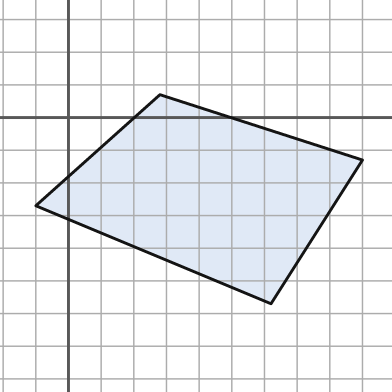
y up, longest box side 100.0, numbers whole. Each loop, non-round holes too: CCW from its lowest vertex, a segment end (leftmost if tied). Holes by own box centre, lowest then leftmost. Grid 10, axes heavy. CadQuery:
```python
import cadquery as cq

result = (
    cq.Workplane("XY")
    .moveTo(62.0, -57.0)
    .lineTo(90.0, -13.0)
    .lineTo(28.0, 7.0)
    .lineTo(-10.0, -27.0)
    .close()
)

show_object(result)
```